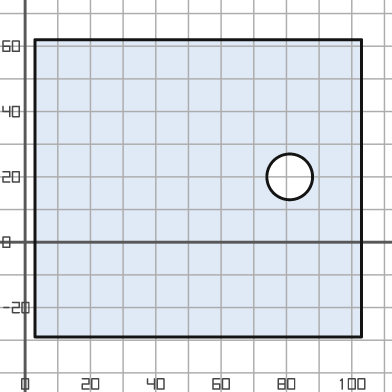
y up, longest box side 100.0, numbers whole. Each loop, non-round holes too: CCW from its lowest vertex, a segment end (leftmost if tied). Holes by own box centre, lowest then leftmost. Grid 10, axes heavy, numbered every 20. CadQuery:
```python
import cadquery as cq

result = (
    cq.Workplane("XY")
    .moveTo(3.0, -29.0)
    .lineTo(103.0, -29.0)
    .lineTo(103.0, 62.0)
    .lineTo(3.0, 62.0)
    .close()
    .moveTo(81.0, 20.0)
    .circle(7.0)
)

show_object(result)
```